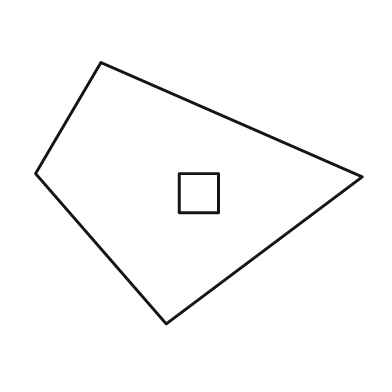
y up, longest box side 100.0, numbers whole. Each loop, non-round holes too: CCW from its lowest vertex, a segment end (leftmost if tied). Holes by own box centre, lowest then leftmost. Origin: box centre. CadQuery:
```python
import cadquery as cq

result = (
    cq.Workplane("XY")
    .moveTo(-10.0, -40.0)
    .lineTo(50.0, 5.0)
    .lineTo(-30.0, 40.0)
    .lineTo(-50.0, 6.0)
    .close()
    .moveTo(-6.0, -6.0)
    .lineTo(6.0, -6.0)
    .lineTo(6.0, 6.0)
    .lineTo(-6.0, 6.0)
    .close()
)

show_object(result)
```